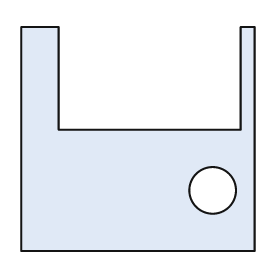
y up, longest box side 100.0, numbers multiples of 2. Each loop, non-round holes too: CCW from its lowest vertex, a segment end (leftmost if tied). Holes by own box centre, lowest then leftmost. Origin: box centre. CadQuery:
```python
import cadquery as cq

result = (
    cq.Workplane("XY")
    .moveTo(-50.0, -48.0)
    .lineTo(50.0, -48.0)
    .lineTo(50.0, 48.0)
    .lineTo(44.0, 48.0)
    .lineTo(44.0, 4.0)
    .lineTo(-34.0, 4.0)
    .lineTo(-34.0, 48.0)
    .lineTo(-50.0, 48.0)
    .close()
    .moveTo(32.0, -22.0)
    .circle(10.0)
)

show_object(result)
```